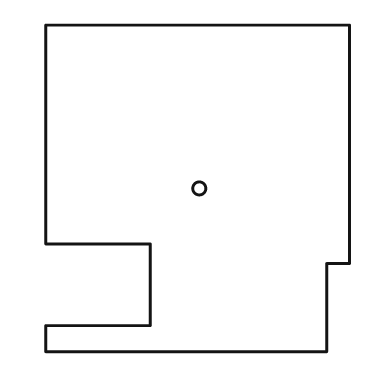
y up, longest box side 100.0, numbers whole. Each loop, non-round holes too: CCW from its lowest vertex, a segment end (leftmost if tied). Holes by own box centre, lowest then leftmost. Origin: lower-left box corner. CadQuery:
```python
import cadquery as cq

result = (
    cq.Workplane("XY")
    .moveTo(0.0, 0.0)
    .lineTo(86.0, 0.0)
    .lineTo(86.0, 27.0)
    .lineTo(93.0, 27.0)
    .lineTo(93.0, 100.0)
    .lineTo(0.0, 100.0)
    .lineTo(0.0, 33.0)
    .lineTo(32.0, 33.0)
    .lineTo(32.0, 8.0)
    .lineTo(0.0, 8.0)
    .close()
    .moveTo(47.0, 50.0)
    .circle(2.0)
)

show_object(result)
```